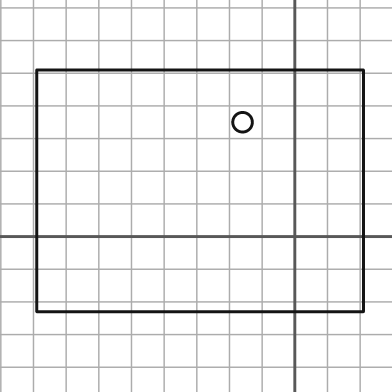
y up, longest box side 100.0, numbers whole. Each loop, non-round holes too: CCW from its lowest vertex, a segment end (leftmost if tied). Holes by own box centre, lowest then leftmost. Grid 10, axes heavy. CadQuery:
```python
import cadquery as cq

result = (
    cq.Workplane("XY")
    .moveTo(-79.0, -23.0)
    .lineTo(21.0, -23.0)
    .lineTo(21.0, 51.0)
    .lineTo(-79.0, 51.0)
    .close()
    .moveTo(-16.0, 35.0)
    .circle(3.0)
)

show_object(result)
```